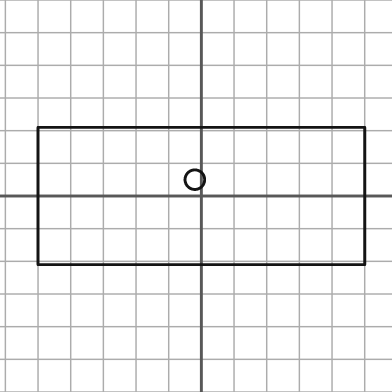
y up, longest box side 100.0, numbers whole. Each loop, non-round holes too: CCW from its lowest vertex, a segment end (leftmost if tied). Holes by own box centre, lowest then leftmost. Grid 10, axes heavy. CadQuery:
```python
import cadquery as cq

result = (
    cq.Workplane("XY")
    .moveTo(-50.0, -21.0)
    .lineTo(50.0, -21.0)
    .lineTo(50.0, 21.0)
    .lineTo(-50.0, 21.0)
    .close()
    .moveTo(-2.0, 5.0)
    .circle(3.0)
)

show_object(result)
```